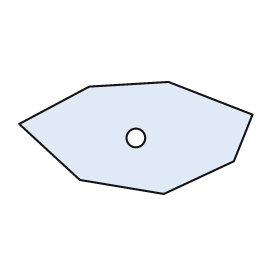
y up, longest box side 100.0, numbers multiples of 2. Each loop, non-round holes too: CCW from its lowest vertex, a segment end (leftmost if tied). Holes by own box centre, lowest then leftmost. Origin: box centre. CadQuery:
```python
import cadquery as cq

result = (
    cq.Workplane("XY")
    .moveTo(12.0, -24.0)
    .lineTo(42.0, -10.0)
    .lineTo(50.0, 10.0)
    .lineTo(14.0, 24.0)
    .lineTo(-20.0, 22.0)
    .lineTo(-50.0, 6.0)
    .lineTo(-24.0, -18.0)
    .close()
    .moveTo(0.0, 0.0)
    .circle(4.0)
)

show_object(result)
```